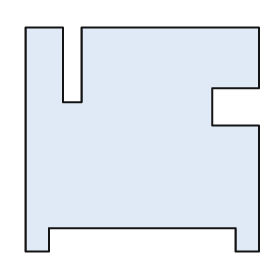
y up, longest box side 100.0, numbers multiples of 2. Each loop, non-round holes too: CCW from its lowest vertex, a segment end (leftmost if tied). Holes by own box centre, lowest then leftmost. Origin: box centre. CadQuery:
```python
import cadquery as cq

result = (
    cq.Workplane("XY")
    .moveTo(-50.0, -48.0)
    .lineTo(-40.0, -48.0)
    .lineTo(-40.0, -38.0)
    .lineTo(40.0, -38.0)
    .lineTo(40.0, -48.0)
    .lineTo(50.0, -48.0)
    .lineTo(50.0, 6.0)
    .lineTo(30.0, 6.0)
    .lineTo(30.0, 22.0)
    .lineTo(50.0, 22.0)
    .lineTo(50.0, 48.0)
    .lineTo(-26.0, 48.0)
    .lineTo(-26.0, 16.0)
    .lineTo(-34.0, 16.0)
    .lineTo(-34.0, 48.0)
    .lineTo(-50.0, 48.0)
    .close()
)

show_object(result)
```